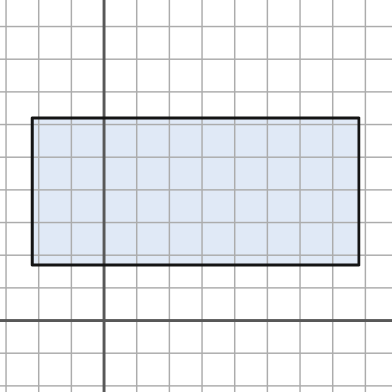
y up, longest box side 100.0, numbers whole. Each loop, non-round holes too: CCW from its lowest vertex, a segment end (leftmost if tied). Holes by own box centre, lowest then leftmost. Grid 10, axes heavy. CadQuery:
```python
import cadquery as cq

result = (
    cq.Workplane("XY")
    .moveTo(-22.0, 17.0)
    .lineTo(78.0, 17.0)
    .lineTo(78.0, 62.0)
    .lineTo(-22.0, 62.0)
    .close()
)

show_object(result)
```